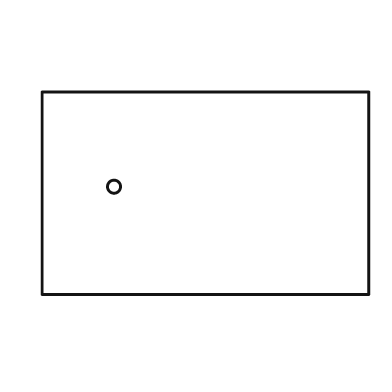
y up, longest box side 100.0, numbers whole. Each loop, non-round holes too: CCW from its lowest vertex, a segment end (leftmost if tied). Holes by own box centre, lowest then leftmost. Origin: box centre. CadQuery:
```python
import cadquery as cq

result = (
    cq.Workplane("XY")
    .moveTo(-50.0, -31.0)
    .lineTo(50.0, -31.0)
    .lineTo(50.0, 31.0)
    .lineTo(-50.0, 31.0)
    .close()
    .moveTo(-28.0, 2.0)
    .circle(2.0)
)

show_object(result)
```